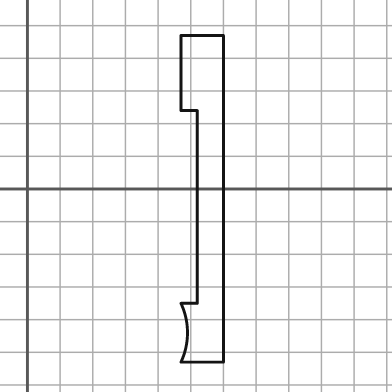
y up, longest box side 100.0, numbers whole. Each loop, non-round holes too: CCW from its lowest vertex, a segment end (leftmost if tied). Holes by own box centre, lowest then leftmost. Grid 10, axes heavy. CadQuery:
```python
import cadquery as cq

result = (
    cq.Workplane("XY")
    .moveTo(47.0, -53.0)
    .lineTo(60.0, -53.0)
    .lineTo(60.0, 47.0)
    .lineTo(47.0, 47.0)
    .lineTo(47.0, 24.0)
    .lineTo(52.0, 24.0)
    .lineTo(52.0, -35.0)
    .lineTo(47.0, -35.0)
    .threePointArc((49.0, -44.0), (47.0, -53.0))
    .close()
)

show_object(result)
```